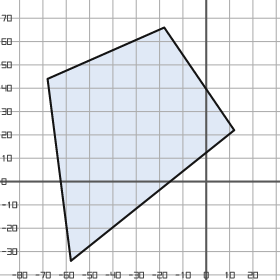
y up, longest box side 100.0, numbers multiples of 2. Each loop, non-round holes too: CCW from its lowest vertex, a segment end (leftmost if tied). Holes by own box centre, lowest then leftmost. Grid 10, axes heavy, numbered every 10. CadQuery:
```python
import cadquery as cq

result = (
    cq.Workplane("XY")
    .moveTo(-58.0, -34.0)
    .lineTo(12.0, 22.0)
    .lineTo(-18.0, 66.0)
    .lineTo(-68.0, 44.0)
    .close()
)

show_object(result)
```